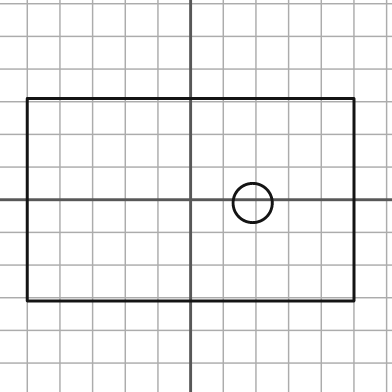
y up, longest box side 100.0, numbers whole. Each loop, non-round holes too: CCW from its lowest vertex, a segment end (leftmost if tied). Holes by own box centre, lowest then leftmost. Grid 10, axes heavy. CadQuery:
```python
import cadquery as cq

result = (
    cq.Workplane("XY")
    .moveTo(-50.0, -31.0)
    .lineTo(50.0, -31.0)
    .lineTo(50.0, 31.0)
    .lineTo(-50.0, 31.0)
    .close()
    .moveTo(19.0, -1.0)
    .circle(6.0)
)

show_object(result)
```